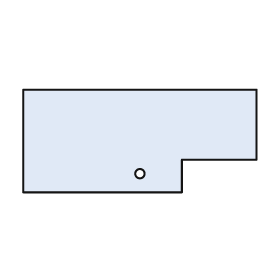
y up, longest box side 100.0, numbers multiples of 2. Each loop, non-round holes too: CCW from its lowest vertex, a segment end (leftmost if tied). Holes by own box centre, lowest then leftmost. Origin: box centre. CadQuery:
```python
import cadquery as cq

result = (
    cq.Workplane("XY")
    .moveTo(-50.0, -22.0)
    .lineTo(18.0, -22.0)
    .lineTo(18.0, -8.0)
    .lineTo(50.0, -8.0)
    .lineTo(50.0, 22.0)
    .lineTo(-50.0, 22.0)
    .close()
    .moveTo(0.0, -14.0)
    .circle(2.0)
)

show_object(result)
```